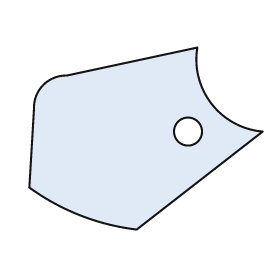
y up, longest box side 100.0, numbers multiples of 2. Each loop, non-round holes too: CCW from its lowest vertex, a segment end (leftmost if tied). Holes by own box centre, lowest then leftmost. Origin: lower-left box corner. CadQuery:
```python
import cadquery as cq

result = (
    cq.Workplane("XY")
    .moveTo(46.0, 0.0)
    .lineTo(100.0, 42.0)
    .threePointArc((78.0, 54.0), (72.0, 78.0))
    .lineTo(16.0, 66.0)
    .threePointArc((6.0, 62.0), (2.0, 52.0))
    .lineTo(0.0, 18.0)
    .threePointArc((22.0, 6.0), (46.0, 0.0))
    .close()
    .moveTo(68.0, 42.0)
    .circle(6.0)
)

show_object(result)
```